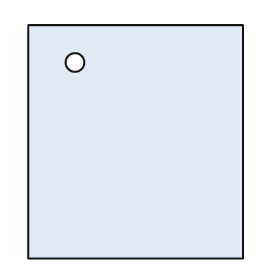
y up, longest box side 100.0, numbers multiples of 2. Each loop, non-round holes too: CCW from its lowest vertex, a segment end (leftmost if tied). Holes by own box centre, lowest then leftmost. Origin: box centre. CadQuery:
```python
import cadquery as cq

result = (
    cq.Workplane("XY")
    .moveTo(-46.0, -50.0)
    .lineTo(46.0, -50.0)
    .lineTo(46.0, 50.0)
    .lineTo(-46.0, 50.0)
    .close()
    .moveTo(-26.0, 34.0)
    .circle(4.0)
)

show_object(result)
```